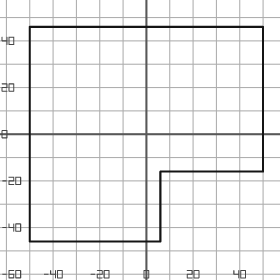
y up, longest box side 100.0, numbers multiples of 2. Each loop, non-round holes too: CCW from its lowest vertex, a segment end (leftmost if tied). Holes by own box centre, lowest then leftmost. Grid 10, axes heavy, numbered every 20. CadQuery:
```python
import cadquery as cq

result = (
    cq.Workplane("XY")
    .moveTo(-50.0, -46.0)
    .lineTo(6.0, -46.0)
    .lineTo(6.0, -16.0)
    .lineTo(50.0, -16.0)
    .lineTo(50.0, 46.0)
    .lineTo(-50.0, 46.0)
    .close()
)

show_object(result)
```